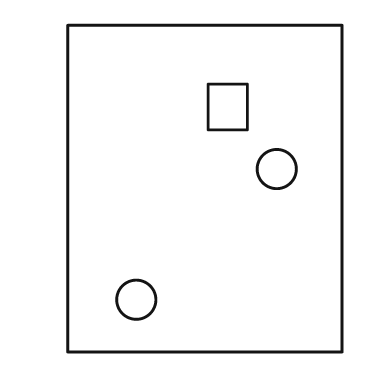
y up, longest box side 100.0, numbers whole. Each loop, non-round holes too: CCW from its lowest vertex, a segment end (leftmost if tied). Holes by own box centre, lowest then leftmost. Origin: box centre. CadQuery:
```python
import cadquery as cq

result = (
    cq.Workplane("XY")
    .moveTo(-42.0, -50.0)
    .lineTo(42.0, -50.0)
    .lineTo(42.0, 50.0)
    .lineTo(-42.0, 50.0)
    .close()
    .moveTo(-21.0, -34.0)
    .circle(6.0)
    .moveTo(22.0, 6.0)
    .circle(6.0)
    .moveTo(1.0, 18.0)
    .lineTo(13.0, 18.0)
    .lineTo(13.0, 32.0)
    .lineTo(1.0, 32.0)
    .close()
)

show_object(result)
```